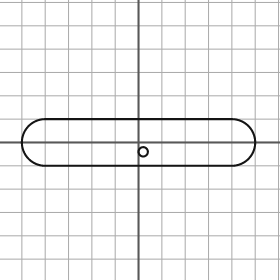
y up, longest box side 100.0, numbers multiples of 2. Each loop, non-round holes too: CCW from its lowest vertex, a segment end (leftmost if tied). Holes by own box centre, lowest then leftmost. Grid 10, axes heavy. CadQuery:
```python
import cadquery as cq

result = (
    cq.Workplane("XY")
    .moveTo(-40.0, -10.0)
    .lineTo(40.0, -10.0)
    .threePointArc((50.0, 0.0), (40.0, 10.0))
    .lineTo(-40.0, 10.0)
    .threePointArc((-50.0, 0.0), (-40.0, -10.0))
    .close()
    .moveTo(2.0, -4.0)
    .circle(2.0)
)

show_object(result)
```